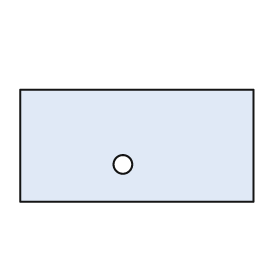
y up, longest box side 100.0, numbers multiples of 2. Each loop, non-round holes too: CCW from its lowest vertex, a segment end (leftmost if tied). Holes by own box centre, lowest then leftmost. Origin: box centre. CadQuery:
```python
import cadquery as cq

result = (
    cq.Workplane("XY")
    .moveTo(-50.0, -24.0)
    .lineTo(50.0, -24.0)
    .lineTo(50.0, 24.0)
    .lineTo(-50.0, 24.0)
    .close()
    .moveTo(-6.0, -8.0)
    .circle(4.0)
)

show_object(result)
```